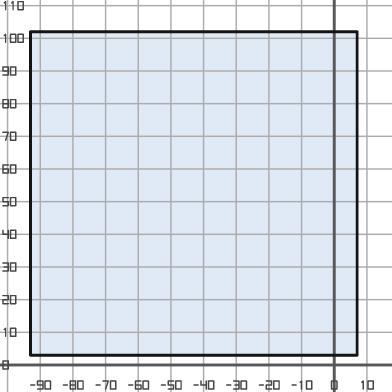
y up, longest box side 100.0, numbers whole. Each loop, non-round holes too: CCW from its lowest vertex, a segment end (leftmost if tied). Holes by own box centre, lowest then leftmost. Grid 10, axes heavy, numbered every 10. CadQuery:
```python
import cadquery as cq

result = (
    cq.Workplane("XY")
    .moveTo(-93.0, 3.0)
    .lineTo(7.0, 3.0)
    .lineTo(7.0, 102.0)
    .lineTo(-93.0, 102.0)
    .close()
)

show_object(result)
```